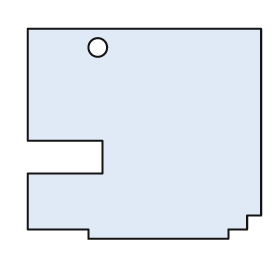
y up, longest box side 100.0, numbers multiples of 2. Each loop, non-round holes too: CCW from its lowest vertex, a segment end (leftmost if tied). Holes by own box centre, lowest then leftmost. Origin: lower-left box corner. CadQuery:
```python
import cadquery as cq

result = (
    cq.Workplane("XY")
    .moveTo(26.0, 0.0)
    .lineTo(86.0, 0.0)
    .lineTo(86.0, 4.0)
    .lineTo(94.0, 4.0)
    .lineTo(94.0, 10.0)
    .lineTo(100.0, 10.0)
    .lineTo(100.0, 90.0)
    .lineTo(0.0, 90.0)
    .lineTo(0.0, 42.0)
    .lineTo(32.0, 42.0)
    .lineTo(32.0, 28.0)
    .lineTo(0.0, 28.0)
    .lineTo(0.0, 4.0)
    .lineTo(26.0, 4.0)
    .close()
    .moveTo(30.0, 82.0)
    .circle(4.0)
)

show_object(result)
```